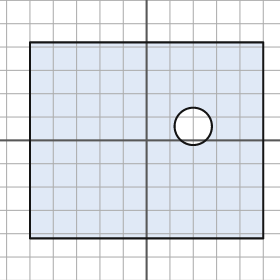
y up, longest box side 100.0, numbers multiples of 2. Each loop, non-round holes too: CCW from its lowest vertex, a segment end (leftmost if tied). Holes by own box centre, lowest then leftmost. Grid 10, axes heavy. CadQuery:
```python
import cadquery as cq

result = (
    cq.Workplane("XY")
    .moveTo(-50.0, -42.0)
    .lineTo(50.0, -42.0)
    .lineTo(50.0, 42.0)
    .lineTo(-50.0, 42.0)
    .close()
    .moveTo(20.0, 6.0)
    .circle(8.0)
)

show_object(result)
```